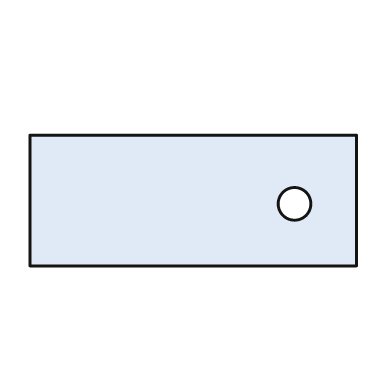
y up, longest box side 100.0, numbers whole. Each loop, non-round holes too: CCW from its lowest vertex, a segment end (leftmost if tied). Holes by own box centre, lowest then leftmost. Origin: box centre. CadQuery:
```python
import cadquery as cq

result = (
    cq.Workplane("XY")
    .moveTo(-50.0, -20.0)
    .lineTo(50.0, -20.0)
    .lineTo(50.0, 20.0)
    .lineTo(-50.0, 20.0)
    .close()
    .moveTo(31.0, -1.0)
    .circle(5.0)
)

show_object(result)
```